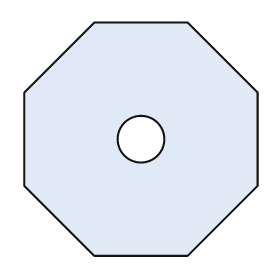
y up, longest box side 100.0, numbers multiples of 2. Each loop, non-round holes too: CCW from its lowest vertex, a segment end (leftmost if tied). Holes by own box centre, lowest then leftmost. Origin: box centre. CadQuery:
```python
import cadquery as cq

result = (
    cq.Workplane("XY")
    .moveTo(-20.0, -50.0)
    .lineTo(20.0, -50.0)
    .lineTo(50.0, -20.0)
    .lineTo(50.0, 20.0)
    .lineTo(20.0, 50.0)
    .lineTo(-20.0, 50.0)
    .lineTo(-50.0, 20.0)
    .lineTo(-50.0, -20.0)
    .close()
    .moveTo(0.0, 0.0)
    .circle(10.0)
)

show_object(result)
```